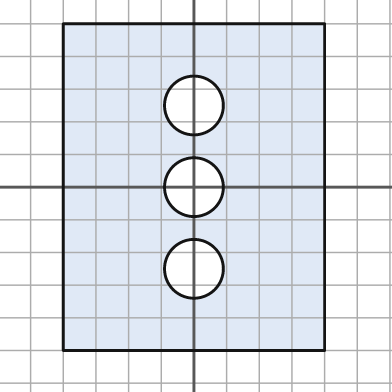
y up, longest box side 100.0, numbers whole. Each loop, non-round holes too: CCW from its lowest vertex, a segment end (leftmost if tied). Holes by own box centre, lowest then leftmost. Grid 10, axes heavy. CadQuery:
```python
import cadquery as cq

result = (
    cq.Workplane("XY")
    .moveTo(-40.0, -50.0)
    .lineTo(40.0, -50.0)
    .lineTo(40.0, 50.0)
    .lineTo(-40.0, 50.0)
    .close()
    .moveTo(0.0, -25.0)
    .circle(9.0)
    .moveTo(0.0, 0.0)
    .circle(9.0)
    .moveTo(0.0, 25.0)
    .circle(9.0)
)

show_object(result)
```